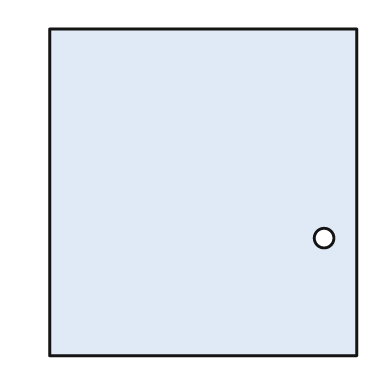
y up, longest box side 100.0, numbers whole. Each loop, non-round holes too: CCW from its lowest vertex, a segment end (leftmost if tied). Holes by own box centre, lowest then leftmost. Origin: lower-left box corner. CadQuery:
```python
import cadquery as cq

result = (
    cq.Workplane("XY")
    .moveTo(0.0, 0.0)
    .lineTo(94.0, 0.0)
    .lineTo(94.0, 100.0)
    .lineTo(0.0, 100.0)
    .close()
    .moveTo(84.0, 36.0)
    .circle(3.0)
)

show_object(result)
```